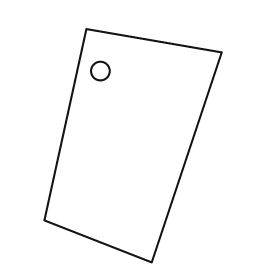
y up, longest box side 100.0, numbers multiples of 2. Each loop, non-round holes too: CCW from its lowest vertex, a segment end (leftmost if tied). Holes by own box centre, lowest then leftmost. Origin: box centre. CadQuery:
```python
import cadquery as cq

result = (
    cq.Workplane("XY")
    .moveTo(8.0, -50.0)
    .lineTo(38.0, 40.0)
    .lineTo(-20.0, 50.0)
    .lineTo(-38.0, -32.0)
    .close()
    .moveTo(-14.0, 32.0)
    .circle(4.0)
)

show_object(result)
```